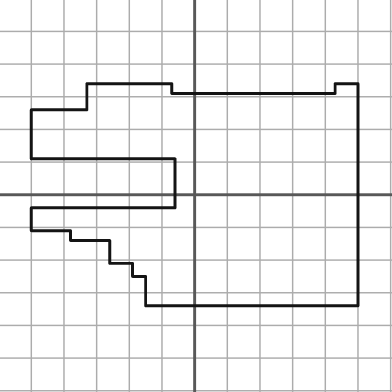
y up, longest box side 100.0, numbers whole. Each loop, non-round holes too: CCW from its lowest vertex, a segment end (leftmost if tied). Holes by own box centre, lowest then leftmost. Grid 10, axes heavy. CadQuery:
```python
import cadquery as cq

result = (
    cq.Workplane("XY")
    .moveTo(-15.0, -34.0)
    .lineTo(50.0, -34.0)
    .lineTo(50.0, 34.0)
    .lineTo(43.0, 34.0)
    .lineTo(43.0, 31.0)
    .lineTo(-7.0, 31.0)
    .lineTo(-7.0, 34.0)
    .lineTo(-33.0, 34.0)
    .lineTo(-33.0, 26.0)
    .lineTo(-50.0, 26.0)
    .lineTo(-50.0, 11.0)
    .lineTo(-6.0, 11.0)
    .lineTo(-6.0, -4.0)
    .lineTo(-50.0, -4.0)
    .lineTo(-50.0, -11.0)
    .lineTo(-38.0, -11.0)
    .lineTo(-38.0, -14.0)
    .lineTo(-26.0, -14.0)
    .lineTo(-26.0, -21.0)
    .lineTo(-19.0, -21.0)
    .lineTo(-19.0, -25.0)
    .lineTo(-15.0, -25.0)
    .close()
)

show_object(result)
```